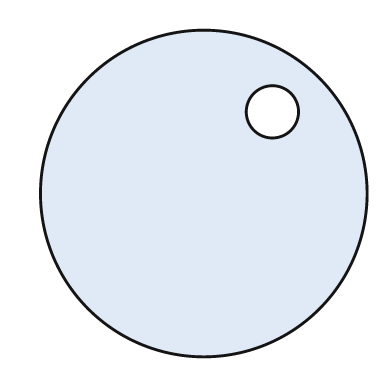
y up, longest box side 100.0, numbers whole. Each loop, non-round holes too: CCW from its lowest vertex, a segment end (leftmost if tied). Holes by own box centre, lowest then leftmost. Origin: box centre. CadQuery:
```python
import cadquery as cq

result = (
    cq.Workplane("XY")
    .moveTo(0.0, 0.0)
    .circle(50.0)
    .moveTo(21.0, 25.0)
    .circle(8.0)
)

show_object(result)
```